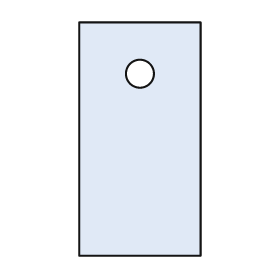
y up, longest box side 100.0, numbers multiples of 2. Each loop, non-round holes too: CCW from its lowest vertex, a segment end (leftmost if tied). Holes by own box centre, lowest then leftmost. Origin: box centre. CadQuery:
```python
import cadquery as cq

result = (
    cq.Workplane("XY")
    .moveTo(-26.0, -50.0)
    .lineTo(26.0, -50.0)
    .lineTo(26.0, 50.0)
    .lineTo(-26.0, 50.0)
    .close()
    .moveTo(0.0, 28.0)
    .circle(6.0)
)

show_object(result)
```